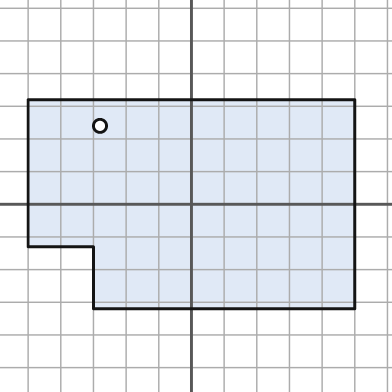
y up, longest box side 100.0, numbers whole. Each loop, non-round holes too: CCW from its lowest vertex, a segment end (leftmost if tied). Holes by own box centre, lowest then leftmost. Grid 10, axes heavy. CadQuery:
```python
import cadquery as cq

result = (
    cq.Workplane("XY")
    .moveTo(-30.0, -32.0)
    .lineTo(50.0, -32.0)
    .lineTo(50.0, 32.0)
    .lineTo(-50.0, 32.0)
    .lineTo(-50.0, -13.0)
    .lineTo(-30.0, -13.0)
    .close()
    .moveTo(-28.0, 24.0)
    .circle(2.0)
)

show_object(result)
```